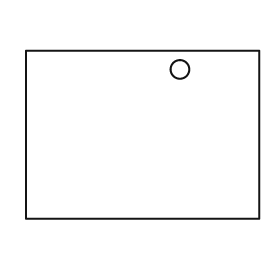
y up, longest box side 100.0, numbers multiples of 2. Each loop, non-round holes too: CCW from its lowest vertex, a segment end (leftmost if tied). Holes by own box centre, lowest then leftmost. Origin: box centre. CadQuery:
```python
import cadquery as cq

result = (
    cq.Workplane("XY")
    .moveTo(-50.0, -36.0)
    .lineTo(50.0, -36.0)
    .lineTo(50.0, 36.0)
    .lineTo(-50.0, 36.0)
    .close()
    .moveTo(16.0, 28.0)
    .circle(4.0)
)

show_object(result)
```